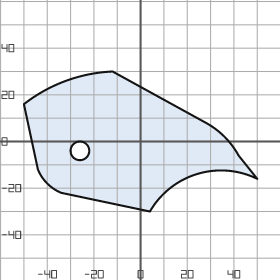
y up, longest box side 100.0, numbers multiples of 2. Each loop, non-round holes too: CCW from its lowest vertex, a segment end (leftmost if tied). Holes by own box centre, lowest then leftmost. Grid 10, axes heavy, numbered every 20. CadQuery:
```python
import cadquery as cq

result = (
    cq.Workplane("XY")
    .moveTo(4.0, -30.0)
    .threePointArc((24.0, -14.0), (50.0, -16.0))
    .lineTo(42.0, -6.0)
    .threePointArc((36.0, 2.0), (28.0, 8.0))
    .lineTo(-12.0, 30.0)
    .threePointArc((-32.0, 26.0), (-50.0, 16.0))
    .lineTo(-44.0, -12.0)
    .threePointArc((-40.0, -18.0), (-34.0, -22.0))
    .close()
    .moveTo(-26.0, -4.0)
    .circle(4.0)
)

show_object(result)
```